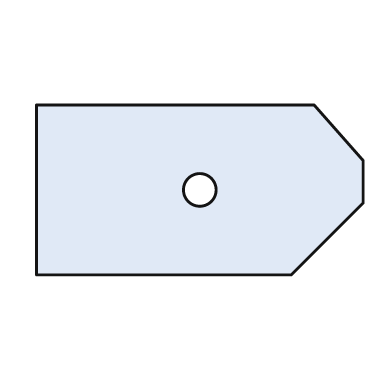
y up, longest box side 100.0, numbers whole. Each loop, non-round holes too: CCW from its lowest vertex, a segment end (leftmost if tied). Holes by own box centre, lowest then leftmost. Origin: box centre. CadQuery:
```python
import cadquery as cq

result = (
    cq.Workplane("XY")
    .moveTo(-50.0, -26.0)
    .lineTo(28.0, -26.0)
    .lineTo(50.0, -4.0)
    .lineTo(50.0, 9.0)
    .lineTo(35.0, 26.0)
    .lineTo(-50.0, 26.0)
    .close()
    .moveTo(0.0, 0.0)
    .circle(5.0)
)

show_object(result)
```